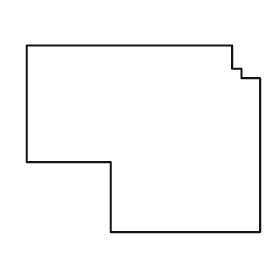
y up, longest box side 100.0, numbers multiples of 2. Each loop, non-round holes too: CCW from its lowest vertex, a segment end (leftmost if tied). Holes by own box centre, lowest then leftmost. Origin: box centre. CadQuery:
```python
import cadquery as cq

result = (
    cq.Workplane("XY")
    .moveTo(-14.0, -40.0)
    .lineTo(50.0, -40.0)
    .lineTo(50.0, 26.0)
    .lineTo(42.0, 26.0)
    .lineTo(42.0, 30.0)
    .lineTo(38.0, 30.0)
    .lineTo(38.0, 40.0)
    .lineTo(-50.0, 40.0)
    .lineTo(-50.0, -10.0)
    .lineTo(-14.0, -10.0)
    .close()
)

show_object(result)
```